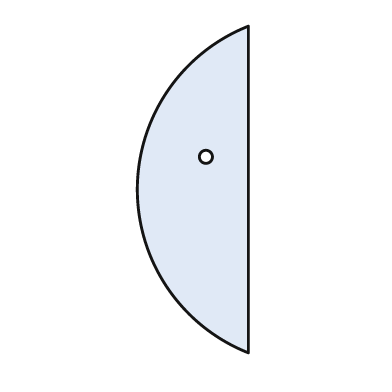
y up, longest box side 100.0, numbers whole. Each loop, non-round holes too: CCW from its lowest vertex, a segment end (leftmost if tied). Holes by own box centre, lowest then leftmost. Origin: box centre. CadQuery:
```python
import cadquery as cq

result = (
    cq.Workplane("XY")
    .moveTo(17.0, -50.0)
    .lineTo(17.0, 50.0)
    .threePointArc((-17.0, 0.0), (17.0, -50.0))
    .close()
    .moveTo(4.0, 10.0)
    .circle(2.0)
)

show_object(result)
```